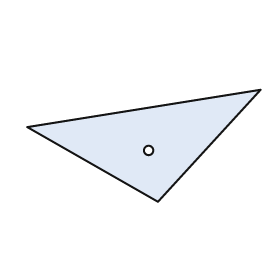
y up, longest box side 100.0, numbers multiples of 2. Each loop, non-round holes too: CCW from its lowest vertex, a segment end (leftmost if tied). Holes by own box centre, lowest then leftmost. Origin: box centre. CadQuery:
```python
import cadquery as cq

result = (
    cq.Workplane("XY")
    .moveTo(6.0, -24.0)
    .lineTo(50.0, 24.0)
    .lineTo(-50.0, 8.0)
    .close()
    .moveTo(2.0, -2.0)
    .circle(2.0)
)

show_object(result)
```